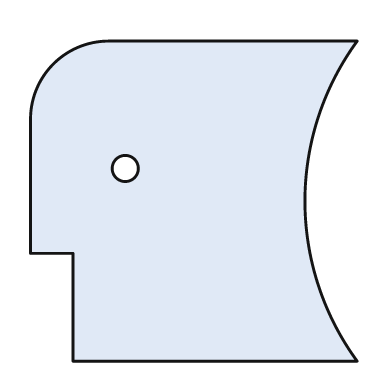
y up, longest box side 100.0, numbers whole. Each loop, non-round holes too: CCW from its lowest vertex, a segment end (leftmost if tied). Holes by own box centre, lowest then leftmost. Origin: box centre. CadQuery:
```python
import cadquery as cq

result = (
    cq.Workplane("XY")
    .moveTo(-37.0, -49.0)
    .lineTo(50.0, -49.0)
    .threePointArc((34.0, 0.0), (50.0, 49.0))
    .lineTo(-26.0, 49.0)
    .threePointArc((-43.0, 42.0), (-50.0, 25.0))
    .lineTo(-50.0, -16.0)
    .lineTo(-37.0, -16.0)
    .close()
    .moveTo(-21.0, 10.0)
    .circle(4.0)
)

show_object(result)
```